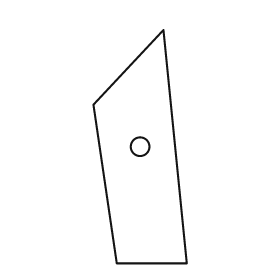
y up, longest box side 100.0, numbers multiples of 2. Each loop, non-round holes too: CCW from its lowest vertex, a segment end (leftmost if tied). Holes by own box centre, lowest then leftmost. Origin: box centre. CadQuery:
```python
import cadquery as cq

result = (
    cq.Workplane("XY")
    .moveTo(-10.0, -50.0)
    .lineTo(20.0, -50.0)
    .lineTo(10.0, 50.0)
    .lineTo(-20.0, 18.0)
    .close()
    .moveTo(0.0, 0.0)
    .circle(4.0)
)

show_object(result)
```